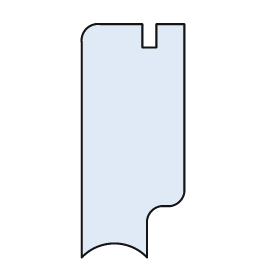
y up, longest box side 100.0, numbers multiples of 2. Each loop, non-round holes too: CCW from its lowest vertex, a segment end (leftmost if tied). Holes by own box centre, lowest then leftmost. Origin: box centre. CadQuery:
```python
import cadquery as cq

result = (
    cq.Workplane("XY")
    .moveTo(-22.0, -50.0)
    .threePointArc((-8.0, -44.0), (6.0, -50.0))
    .lineTo(6.0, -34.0)
    .threePointArc((8.0, -30.0), (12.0, -28.0))
    .lineTo(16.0, -28.0)
    .threePointArc((20.0, -26.0), (22.0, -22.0))
    .lineTo(22.0, 50.0)
    .lineTo(10.0, 50.0)
    .lineTo(10.0, 40.0)
    .lineTo(4.0, 40.0)
    .lineTo(4.0, 50.0)
    .lineTo(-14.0, 50.0)
    .threePointArc((-20.0, 48.0), (-22.0, 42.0))
    .close()
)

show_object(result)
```